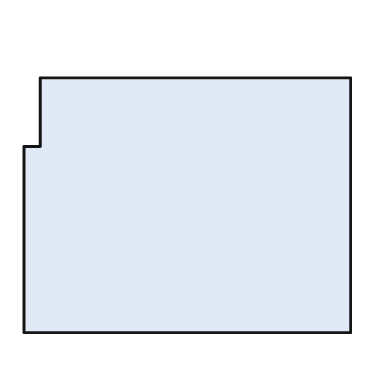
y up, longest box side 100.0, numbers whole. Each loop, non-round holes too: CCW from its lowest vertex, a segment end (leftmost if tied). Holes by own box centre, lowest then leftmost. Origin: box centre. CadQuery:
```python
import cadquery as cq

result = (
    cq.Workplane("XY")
    .moveTo(-50.0, -39.0)
    .lineTo(50.0, -39.0)
    .lineTo(50.0, 39.0)
    .lineTo(-45.0, 39.0)
    .lineTo(-45.0, 18.0)
    .lineTo(-50.0, 18.0)
    .close()
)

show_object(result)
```